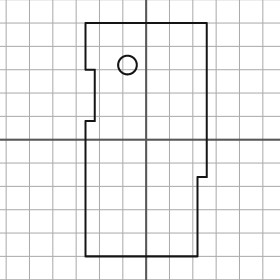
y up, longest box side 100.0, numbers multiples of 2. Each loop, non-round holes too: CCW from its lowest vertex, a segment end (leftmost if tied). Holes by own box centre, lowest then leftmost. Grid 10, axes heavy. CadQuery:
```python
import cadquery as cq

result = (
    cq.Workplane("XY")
    .moveTo(-26.0, -50.0)
    .lineTo(22.0, -50.0)
    .lineTo(22.0, -16.0)
    .lineTo(26.0, -16.0)
    .lineTo(26.0, 50.0)
    .lineTo(-26.0, 50.0)
    .lineTo(-26.0, 30.0)
    .lineTo(-22.0, 30.0)
    .lineTo(-22.0, 8.0)
    .lineTo(-26.0, 8.0)
    .close()
    .moveTo(-8.0, 32.0)
    .circle(4.0)
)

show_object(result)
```